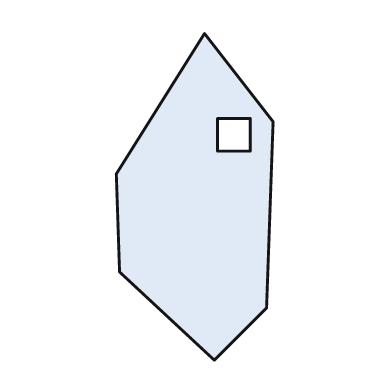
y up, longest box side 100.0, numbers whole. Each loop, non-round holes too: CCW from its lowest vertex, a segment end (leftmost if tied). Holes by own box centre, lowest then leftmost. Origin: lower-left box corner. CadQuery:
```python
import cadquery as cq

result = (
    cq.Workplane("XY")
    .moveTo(30.0, 0.0)
    .lineTo(46.0, 16.0)
    .lineTo(48.0, 73.0)
    .lineTo(27.0, 100.0)
    .lineTo(0.0, 57.0)
    .lineTo(1.0, 27.0)
    .close()
    .moveTo(31.0, 64.0)
    .lineTo(41.0, 64.0)
    .lineTo(41.0, 74.0)
    .lineTo(31.0, 74.0)
    .close()
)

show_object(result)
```